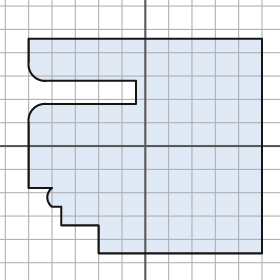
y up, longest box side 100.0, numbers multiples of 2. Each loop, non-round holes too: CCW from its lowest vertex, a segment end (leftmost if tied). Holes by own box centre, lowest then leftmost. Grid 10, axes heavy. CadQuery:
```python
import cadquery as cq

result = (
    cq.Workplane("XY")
    .moveTo(-20.0, -46.0)
    .lineTo(50.0, -46.0)
    .lineTo(50.0, 46.0)
    .lineTo(-50.0, 46.0)
    .lineTo(-50.0, 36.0)
    .threePointArc((-48.0, 30.0), (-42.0, 28.0))
    .lineTo(-4.0, 28.0)
    .lineTo(-4.0, 18.0)
    .lineTo(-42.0, 18.0)
    .threePointArc((-48.0, 16.0), (-50.0, 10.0))
    .lineTo(-50.0, -18.0)
    .lineTo(-40.0, -18.0)
    .threePointArc((-42.0, -22.0), (-40.0, -26.0))
    .lineTo(-36.0, -26.0)
    .lineTo(-36.0, -34.0)
    .lineTo(-20.0, -34.0)
    .close()
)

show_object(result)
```